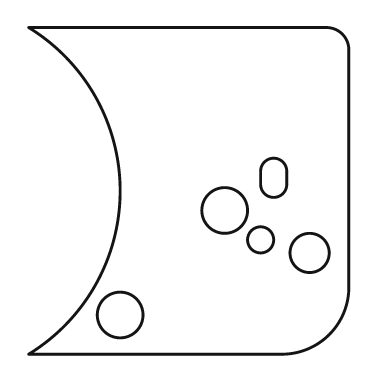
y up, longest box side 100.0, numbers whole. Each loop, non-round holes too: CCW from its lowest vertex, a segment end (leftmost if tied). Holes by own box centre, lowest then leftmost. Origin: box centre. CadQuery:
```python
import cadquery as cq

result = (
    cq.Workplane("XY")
    .moveTo(-49.0, -50.0)
    .lineTo(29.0, -50.0)
    .threePointArc((43.0, -44.0), (49.0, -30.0))
    .lineTo(49.0, 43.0)
    .threePointArc((47.0, 48.0), (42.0, 50.0))
    .lineTo(-49.0, 50.0)
    .threePointArc((-21.0, 0.0), (-49.0, -50.0))
    .close()
    .moveTo(-21.0, -38.0)
    .circle(7.0)
    .moveTo(37.0, -19.0)
    .circle(6.0)
    .moveTo(22.0, -15.0)
    .circle(4.0)
    .moveTo(11.0, -6.0)
    .circle(7.0)
    .moveTo(22.0, 2.0)
    .threePointArc((26.0, -2.0), (30.0, 2.0))
    .lineTo(30.0, 6.0)
    .threePointArc((26.0, 10.0), (22.0, 6.0))
    .close()
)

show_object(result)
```